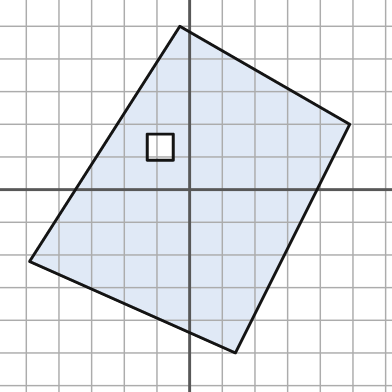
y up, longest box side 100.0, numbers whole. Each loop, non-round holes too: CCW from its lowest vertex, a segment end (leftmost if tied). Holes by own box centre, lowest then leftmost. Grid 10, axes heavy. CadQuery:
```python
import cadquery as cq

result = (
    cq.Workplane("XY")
    .moveTo(14.0, -50.0)
    .lineTo(49.0, 20.0)
    .lineTo(-3.0, 50.0)
    .lineTo(-49.0, -22.0)
    .close()
    .moveTo(-13.0, 9.0)
    .lineTo(-5.0, 9.0)
    .lineTo(-5.0, 17.0)
    .lineTo(-13.0, 17.0)
    .close()
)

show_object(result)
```